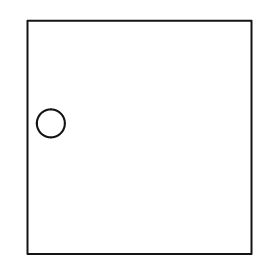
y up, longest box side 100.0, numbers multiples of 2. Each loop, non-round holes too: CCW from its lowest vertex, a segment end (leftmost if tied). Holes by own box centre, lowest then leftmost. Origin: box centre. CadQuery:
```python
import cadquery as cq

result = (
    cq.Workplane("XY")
    .moveTo(-48.0, -50.0)
    .lineTo(48.0, -50.0)
    .lineTo(48.0, 50.0)
    .lineTo(-48.0, 50.0)
    .close()
    .moveTo(-38.0, 6.0)
    .circle(6.0)
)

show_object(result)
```